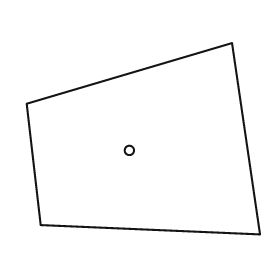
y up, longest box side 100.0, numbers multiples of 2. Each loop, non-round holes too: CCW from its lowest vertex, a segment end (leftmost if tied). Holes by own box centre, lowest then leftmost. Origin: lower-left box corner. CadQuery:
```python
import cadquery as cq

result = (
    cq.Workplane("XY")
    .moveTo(100.0, 0.0)
    .lineTo(88.0, 82.0)
    .lineTo(0.0, 56.0)
    .lineTo(6.0, 4.0)
    .close()
    .moveTo(44.0, 36.0)
    .circle(2.0)
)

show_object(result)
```